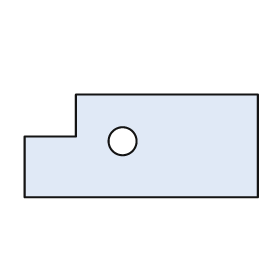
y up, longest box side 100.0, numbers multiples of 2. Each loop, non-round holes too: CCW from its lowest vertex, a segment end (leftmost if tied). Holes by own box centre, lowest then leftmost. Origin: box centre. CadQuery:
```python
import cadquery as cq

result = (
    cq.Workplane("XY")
    .moveTo(-50.0, -22.0)
    .lineTo(50.0, -22.0)
    .lineTo(50.0, 22.0)
    .lineTo(-28.0, 22.0)
    .lineTo(-28.0, 4.0)
    .lineTo(-50.0, 4.0)
    .close()
    .moveTo(-8.0, 2.0)
    .circle(6.0)
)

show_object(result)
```